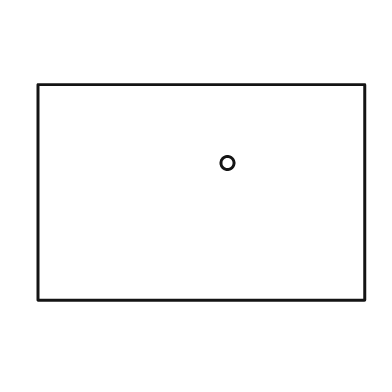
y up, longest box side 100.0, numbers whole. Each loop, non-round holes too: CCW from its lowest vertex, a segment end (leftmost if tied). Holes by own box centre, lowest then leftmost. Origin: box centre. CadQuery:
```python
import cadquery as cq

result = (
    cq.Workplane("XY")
    .moveTo(-50.0, -33.0)
    .lineTo(50.0, -33.0)
    .lineTo(50.0, 33.0)
    .lineTo(-50.0, 33.0)
    .close()
    .moveTo(8.0, 9.0)
    .circle(2.0)
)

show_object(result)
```